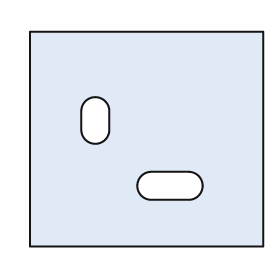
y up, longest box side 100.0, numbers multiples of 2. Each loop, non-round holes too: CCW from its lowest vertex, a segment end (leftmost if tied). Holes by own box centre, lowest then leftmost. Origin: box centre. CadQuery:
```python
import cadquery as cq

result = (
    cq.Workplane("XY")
    .moveTo(-50.0, -46.0)
    .lineTo(50.0, -46.0)
    .lineTo(50.0, 46.0)
    .lineTo(-50.0, 46.0)
    .close()
    .moveTo(2.0, -26.0)
    .lineTo(18.0, -26.0)
    .threePointArc((24.0, -20.0), (18.0, -14.0))
    .lineTo(2.0, -14.0)
    .threePointArc((-4.0, -20.0), (2.0, -26.0))
    .close()
    .moveTo(-28.0, 4.0)
    .threePointArc((-22.0, -2.0), (-16.0, 4.0))
    .lineTo(-16.0, 12.0)
    .threePointArc((-22.0, 18.0), (-28.0, 12.0))
    .close()
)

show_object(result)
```